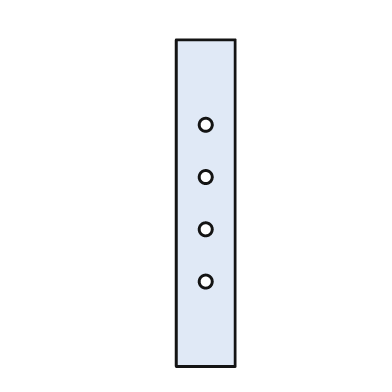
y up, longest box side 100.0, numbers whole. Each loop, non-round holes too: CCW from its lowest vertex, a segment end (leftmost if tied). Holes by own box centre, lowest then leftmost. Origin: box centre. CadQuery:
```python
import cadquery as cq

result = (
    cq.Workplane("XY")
    .moveTo(-9.0, -50.0)
    .lineTo(9.0, -50.0)
    .lineTo(9.0, 50.0)
    .lineTo(-9.0, 50.0)
    .close()
    .moveTo(0.0, -24.0)
    .circle(2.0)
    .moveTo(0.0, -8.0)
    .circle(2.0)
    .moveTo(0.0, 8.0)
    .circle(2.0)
    .moveTo(0.0, 24.0)
    .circle(2.0)
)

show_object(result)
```